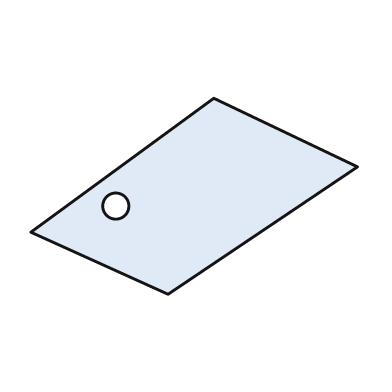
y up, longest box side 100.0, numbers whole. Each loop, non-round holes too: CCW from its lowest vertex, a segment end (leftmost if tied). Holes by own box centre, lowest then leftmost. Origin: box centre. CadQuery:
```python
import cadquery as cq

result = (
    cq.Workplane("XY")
    .moveTo(-8.0, -30.0)
    .lineTo(50.0, 9.0)
    .lineTo(6.0, 30.0)
    .lineTo(-50.0, -11.0)
    .close()
    .moveTo(-24.0, -3.0)
    .circle(4.0)
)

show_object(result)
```